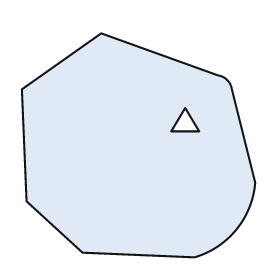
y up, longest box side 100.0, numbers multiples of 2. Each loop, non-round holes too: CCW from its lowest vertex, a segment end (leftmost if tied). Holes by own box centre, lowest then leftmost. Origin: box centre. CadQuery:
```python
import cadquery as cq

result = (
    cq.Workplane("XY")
    .moveTo(24.0, -48.0)
    .threePointArc((42.0, -36.0), (50.0, -16.0))
    .lineTo(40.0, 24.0)
    .threePointArc((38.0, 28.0), (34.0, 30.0))
    .lineTo(-16.0, 48.0)
    .lineTo(-50.0, 24.0)
    .lineTo(-48.0, -24.0)
    .lineTo(-24.0, -46.0)
    .close()
    .moveTo(14.0, 6.0)
    .lineTo(26.0, 6.0)
    .lineTo(20.0, 16.0)
    .close()
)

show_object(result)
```